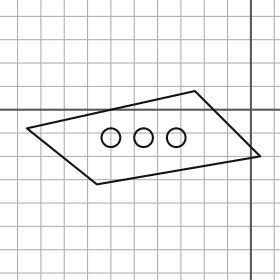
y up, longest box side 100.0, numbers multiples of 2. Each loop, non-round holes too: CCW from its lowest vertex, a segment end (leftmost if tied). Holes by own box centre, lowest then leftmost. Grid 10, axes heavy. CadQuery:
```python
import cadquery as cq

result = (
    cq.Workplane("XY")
    .moveTo(-66.0, -32.0)
    .lineTo(4.0, -20.0)
    .lineTo(-24.0, 8.0)
    .lineTo(-96.0, -8.0)
    .close()
    .moveTo(-60.0, -12.0)
    .circle(4.0)
    .moveTo(-46.0, -12.0)
    .circle(4.0)
    .moveTo(-32.0, -12.0)
    .circle(4.0)
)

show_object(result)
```